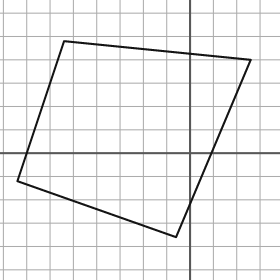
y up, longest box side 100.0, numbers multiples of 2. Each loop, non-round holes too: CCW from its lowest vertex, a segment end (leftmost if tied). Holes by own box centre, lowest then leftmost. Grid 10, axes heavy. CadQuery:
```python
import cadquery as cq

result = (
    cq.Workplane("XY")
    .moveTo(-6.0, -36.0)
    .lineTo(26.0, 40.0)
    .lineTo(-54.0, 48.0)
    .lineTo(-74.0, -12.0)
    .close()
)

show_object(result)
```